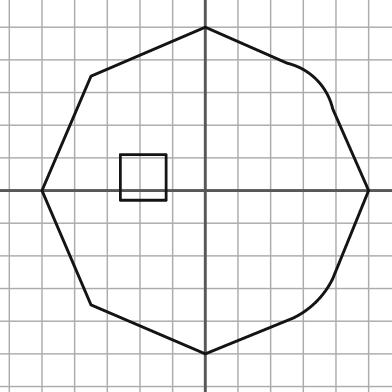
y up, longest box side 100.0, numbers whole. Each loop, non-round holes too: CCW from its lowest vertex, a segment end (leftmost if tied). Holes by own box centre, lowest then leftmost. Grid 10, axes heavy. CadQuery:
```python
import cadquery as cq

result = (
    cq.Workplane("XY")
    .moveTo(0.0, -50.0)
    .lineTo(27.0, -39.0)
    .threePointArc((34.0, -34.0), (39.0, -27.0))
    .lineTo(50.0, 0.0)
    .lineTo(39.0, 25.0)
    .threePointArc((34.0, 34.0), (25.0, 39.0))
    .lineTo(0.0, 50.0)
    .lineTo(-35.0, 35.0)
    .lineTo(-50.0, 0.0)
    .lineTo(-35.0, -35.0)
    .close()
    .moveTo(-26.0, -3.0)
    .lineTo(-12.0, -3.0)
    .lineTo(-12.0, 11.0)
    .lineTo(-26.0, 11.0)
    .close()
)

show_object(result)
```